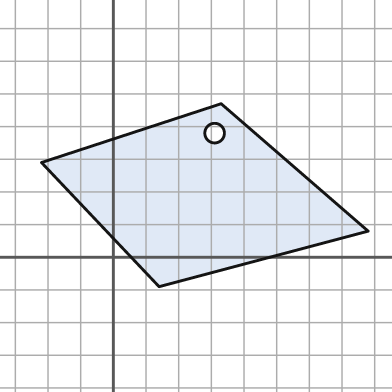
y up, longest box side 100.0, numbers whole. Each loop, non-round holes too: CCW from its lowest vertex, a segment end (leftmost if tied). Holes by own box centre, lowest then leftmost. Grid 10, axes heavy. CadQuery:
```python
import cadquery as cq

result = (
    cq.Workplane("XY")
    .moveTo(14.0, -9.0)
    .lineTo(78.0, 8.0)
    .lineTo(33.0, 47.0)
    .lineTo(-22.0, 29.0)
    .close()
    .moveTo(31.0, 38.0)
    .circle(3.0)
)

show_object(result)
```